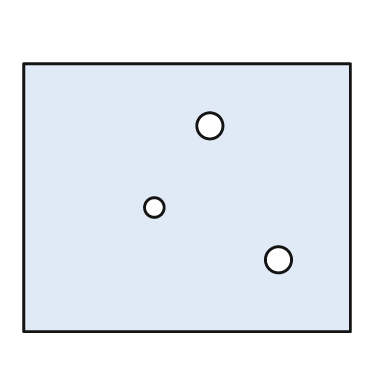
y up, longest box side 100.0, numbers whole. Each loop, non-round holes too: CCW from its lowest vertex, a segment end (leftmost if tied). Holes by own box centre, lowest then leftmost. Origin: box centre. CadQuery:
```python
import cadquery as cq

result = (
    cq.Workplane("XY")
    .moveTo(-50.0, -41.0)
    .lineTo(50.0, -41.0)
    .lineTo(50.0, 41.0)
    .lineTo(-50.0, 41.0)
    .close()
    .moveTo(28.0, -19.0)
    .circle(4.0)
    .moveTo(-10.0, -3.0)
    .circle(3.0)
    .moveTo(7.0, 22.0)
    .circle(4.0)
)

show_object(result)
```